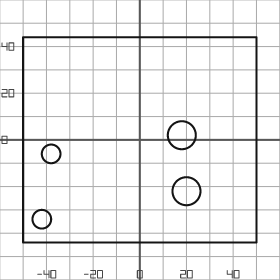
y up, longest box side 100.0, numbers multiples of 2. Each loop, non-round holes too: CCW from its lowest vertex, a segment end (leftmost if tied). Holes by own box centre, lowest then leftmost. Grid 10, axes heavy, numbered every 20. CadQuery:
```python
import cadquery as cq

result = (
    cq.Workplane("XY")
    .moveTo(-50.0, -44.0)
    .lineTo(50.0, -44.0)
    .lineTo(50.0, 44.0)
    .lineTo(-50.0, 44.0)
    .close()
    .moveTo(-42.0, -34.0)
    .circle(4.0)
    .moveTo(20.0, -22.0)
    .circle(6.0)
    .moveTo(-38.0, -6.0)
    .circle(4.0)
    .moveTo(18.0, 2.0)
    .circle(6.0)
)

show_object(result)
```